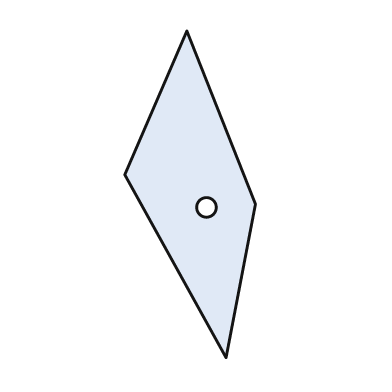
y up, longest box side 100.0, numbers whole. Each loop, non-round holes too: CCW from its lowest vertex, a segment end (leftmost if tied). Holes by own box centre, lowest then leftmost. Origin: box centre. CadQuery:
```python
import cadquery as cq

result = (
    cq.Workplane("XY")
    .moveTo(11.0, -50.0)
    .lineTo(20.0, -3.0)
    .lineTo(-1.0, 50.0)
    .lineTo(-20.0, 6.0)
    .close()
    .moveTo(5.0, -4.0)
    .circle(3.0)
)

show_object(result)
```